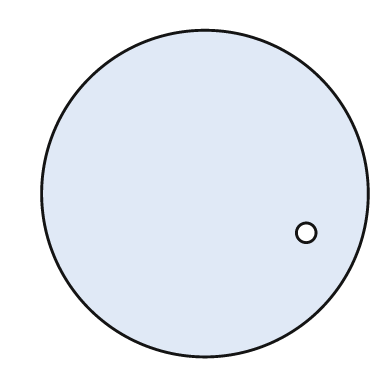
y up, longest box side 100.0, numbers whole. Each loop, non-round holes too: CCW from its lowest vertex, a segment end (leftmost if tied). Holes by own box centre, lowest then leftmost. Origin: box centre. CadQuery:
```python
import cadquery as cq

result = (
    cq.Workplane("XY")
    .moveTo(0.0, 0.0)
    .circle(50.0)
    .moveTo(31.0, -12.0)
    .circle(3.0)
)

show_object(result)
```